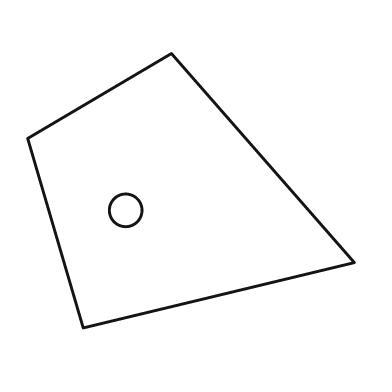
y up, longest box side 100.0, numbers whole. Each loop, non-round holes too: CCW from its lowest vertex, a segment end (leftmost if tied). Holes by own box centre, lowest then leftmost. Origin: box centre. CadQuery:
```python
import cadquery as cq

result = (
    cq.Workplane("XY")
    .moveTo(-33.0, -42.0)
    .lineTo(50.0, -22.0)
    .lineTo(-6.0, 42.0)
    .lineTo(-50.0, 16.0)
    .close()
    .moveTo(-20.0, -6.0)
    .circle(5.0)
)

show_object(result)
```